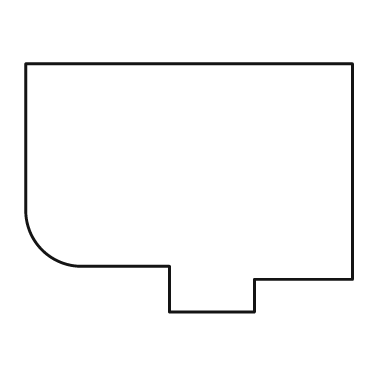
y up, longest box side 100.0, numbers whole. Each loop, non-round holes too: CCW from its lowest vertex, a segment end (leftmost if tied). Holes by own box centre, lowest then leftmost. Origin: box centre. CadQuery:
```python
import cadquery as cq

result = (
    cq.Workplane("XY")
    .moveTo(-6.0, -38.0)
    .lineTo(20.0, -38.0)
    .lineTo(20.0, -28.0)
    .lineTo(50.0, -28.0)
    .lineTo(50.0, 38.0)
    .lineTo(-50.0, 38.0)
    .lineTo(-50.0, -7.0)
    .threePointArc((-45.0, -19.0), (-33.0, -24.0))
    .lineTo(-6.0, -24.0)
    .close()
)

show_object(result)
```